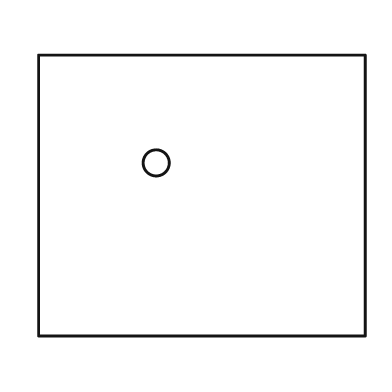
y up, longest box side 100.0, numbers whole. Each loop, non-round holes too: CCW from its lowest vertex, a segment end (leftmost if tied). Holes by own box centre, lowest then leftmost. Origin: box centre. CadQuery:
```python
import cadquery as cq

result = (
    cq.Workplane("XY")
    .moveTo(-50.0, -43.0)
    .lineTo(50.0, -43.0)
    .lineTo(50.0, 43.0)
    .lineTo(-50.0, 43.0)
    .close()
    .moveTo(-14.0, 10.0)
    .circle(4.0)
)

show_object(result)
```